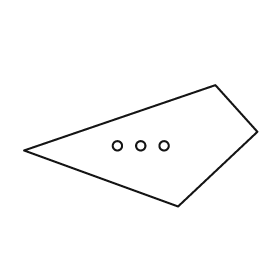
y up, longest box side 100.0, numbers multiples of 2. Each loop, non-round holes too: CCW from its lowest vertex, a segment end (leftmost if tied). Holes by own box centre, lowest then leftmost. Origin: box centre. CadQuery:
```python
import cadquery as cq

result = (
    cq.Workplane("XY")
    .moveTo(16.0, -26.0)
    .lineTo(50.0, 6.0)
    .lineTo(32.0, 26.0)
    .lineTo(-50.0, -2.0)
    .close()
    .moveTo(-10.0, 0.0)
    .circle(2.0)
    .moveTo(0.0, 0.0)
    .circle(2.0)
    .moveTo(10.0, 0.0)
    .circle(2.0)
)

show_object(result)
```